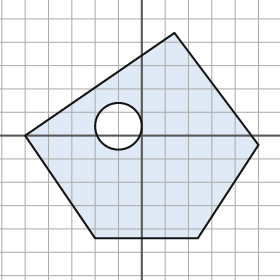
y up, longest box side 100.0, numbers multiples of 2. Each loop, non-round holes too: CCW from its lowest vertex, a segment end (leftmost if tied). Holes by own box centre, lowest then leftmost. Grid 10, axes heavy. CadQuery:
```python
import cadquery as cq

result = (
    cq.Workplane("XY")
    .moveTo(-20.0, -44.0)
    .lineTo(24.0, -44.0)
    .lineTo(50.0, -4.0)
    .lineTo(14.0, 44.0)
    .lineTo(-50.0, 0.0)
    .close()
    .moveTo(-10.0, 4.0)
    .circle(10.0)
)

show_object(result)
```